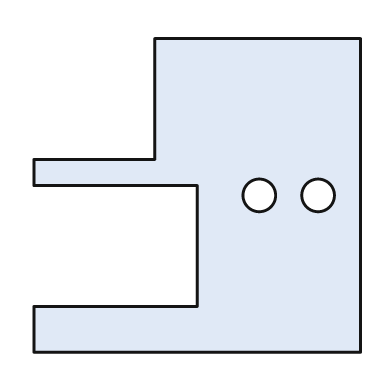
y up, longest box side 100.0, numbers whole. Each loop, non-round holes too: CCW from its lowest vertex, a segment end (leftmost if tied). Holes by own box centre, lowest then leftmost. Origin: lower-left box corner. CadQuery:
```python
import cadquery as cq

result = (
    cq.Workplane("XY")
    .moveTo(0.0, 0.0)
    .lineTo(100.0, 0.0)
    .lineTo(100.0, 96.0)
    .lineTo(37.0, 96.0)
    .lineTo(37.0, 59.0)
    .lineTo(0.0, 59.0)
    .lineTo(0.0, 51.0)
    .lineTo(50.0, 51.0)
    .lineTo(50.0, 14.0)
    .lineTo(0.0, 14.0)
    .close()
    .moveTo(69.0, 48.0)
    .circle(5.0)
    .moveTo(87.0, 48.0)
    .circle(5.0)
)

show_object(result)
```